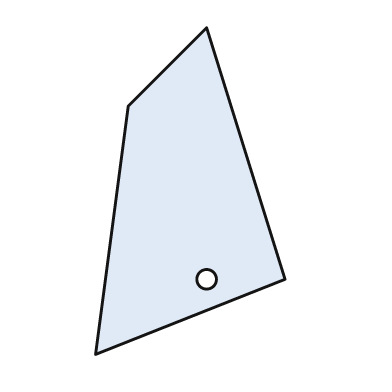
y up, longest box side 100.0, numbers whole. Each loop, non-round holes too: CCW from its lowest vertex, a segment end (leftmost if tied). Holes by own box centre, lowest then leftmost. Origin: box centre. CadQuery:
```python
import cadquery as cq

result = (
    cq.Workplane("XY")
    .moveTo(-29.0, -50.0)
    .lineTo(29.0, -27.0)
    .lineTo(5.0, 50.0)
    .lineTo(-19.0, 26.0)
    .close()
    .moveTo(5.0, -27.0)
    .circle(3.0)
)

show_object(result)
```